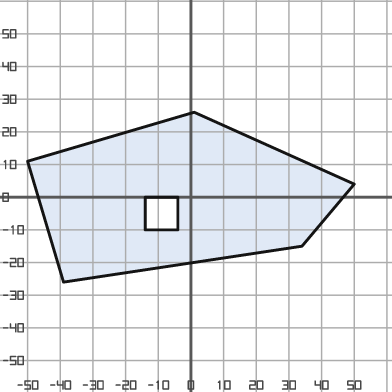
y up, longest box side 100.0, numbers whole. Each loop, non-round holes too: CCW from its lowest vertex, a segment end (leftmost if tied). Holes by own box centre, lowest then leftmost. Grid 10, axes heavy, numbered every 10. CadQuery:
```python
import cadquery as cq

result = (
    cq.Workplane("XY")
    .moveTo(-39.0, -26.0)
    .lineTo(34.0, -15.0)
    .lineTo(50.0, 4.0)
    .lineTo(1.0, 26.0)
    .lineTo(-50.0, 11.0)
    .close()
    .moveTo(-14.0, -10.0)
    .lineTo(-4.0, -10.0)
    .lineTo(-4.0, 0.0)
    .lineTo(-14.0, 0.0)
    .close()
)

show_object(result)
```